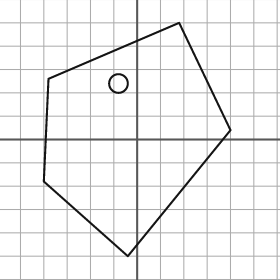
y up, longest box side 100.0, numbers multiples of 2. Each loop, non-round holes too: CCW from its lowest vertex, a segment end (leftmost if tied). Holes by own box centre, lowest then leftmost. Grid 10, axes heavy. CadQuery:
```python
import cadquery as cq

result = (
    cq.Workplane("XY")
    .moveTo(-4.0, -50.0)
    .lineTo(40.0, 4.0)
    .lineTo(18.0, 50.0)
    .lineTo(-38.0, 26.0)
    .lineTo(-40.0, -18.0)
    .close()
    .moveTo(-8.0, 24.0)
    .circle(4.0)
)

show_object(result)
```